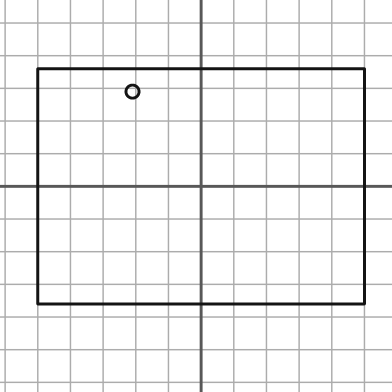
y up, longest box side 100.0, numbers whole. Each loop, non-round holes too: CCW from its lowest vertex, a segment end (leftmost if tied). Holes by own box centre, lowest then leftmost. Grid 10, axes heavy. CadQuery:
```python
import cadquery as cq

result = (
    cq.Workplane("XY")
    .moveTo(-50.0, -36.0)
    .lineTo(50.0, -36.0)
    .lineTo(50.0, 36.0)
    .lineTo(-50.0, 36.0)
    .close()
    .moveTo(-21.0, 29.0)
    .circle(2.0)
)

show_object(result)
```